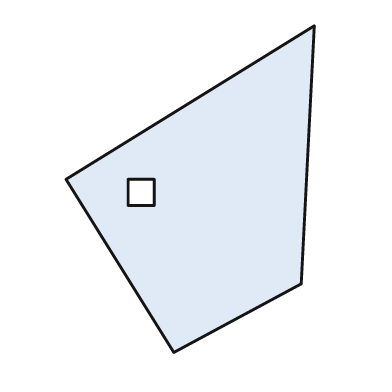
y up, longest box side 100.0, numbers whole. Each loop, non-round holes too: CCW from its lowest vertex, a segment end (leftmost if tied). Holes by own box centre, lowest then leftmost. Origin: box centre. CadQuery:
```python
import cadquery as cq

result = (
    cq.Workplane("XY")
    .moveTo(-5.0, -50.0)
    .lineTo(34.0, -29.0)
    .lineTo(38.0, 50.0)
    .lineTo(-38.0, 3.0)
    .close()
    .moveTo(-19.0, -5.0)
    .lineTo(-11.0, -5.0)
    .lineTo(-11.0, 3.0)
    .lineTo(-19.0, 3.0)
    .close()
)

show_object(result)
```